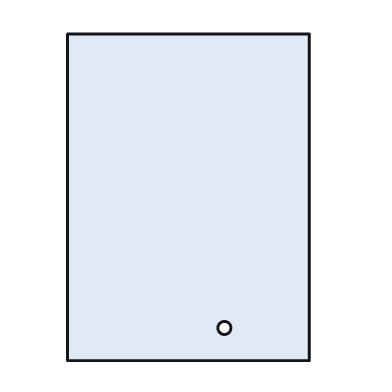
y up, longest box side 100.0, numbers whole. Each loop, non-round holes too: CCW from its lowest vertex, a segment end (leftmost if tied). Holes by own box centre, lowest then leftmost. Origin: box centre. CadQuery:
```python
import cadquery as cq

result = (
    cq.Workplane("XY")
    .moveTo(-37.0, -50.0)
    .lineTo(37.0, -50.0)
    .lineTo(37.0, 50.0)
    .lineTo(-37.0, 50.0)
    .close()
    .moveTo(11.0, -40.0)
    .circle(2.0)
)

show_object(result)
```